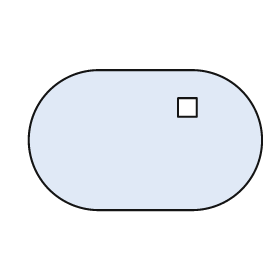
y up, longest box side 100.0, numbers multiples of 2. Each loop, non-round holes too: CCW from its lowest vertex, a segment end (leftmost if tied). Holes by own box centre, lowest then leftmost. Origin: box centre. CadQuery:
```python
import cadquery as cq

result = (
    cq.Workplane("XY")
    .moveTo(-20.0, -30.0)
    .lineTo(20.0, -30.0)
    .threePointArc((50.0, 0.0), (20.0, 30.0))
    .lineTo(-20.0, 30.0)
    .threePointArc((-50.0, 0.0), (-20.0, -30.0))
    .close()
    .moveTo(14.0, 10.0)
    .lineTo(22.0, 10.0)
    .lineTo(22.0, 18.0)
    .lineTo(14.0, 18.0)
    .close()
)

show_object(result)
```